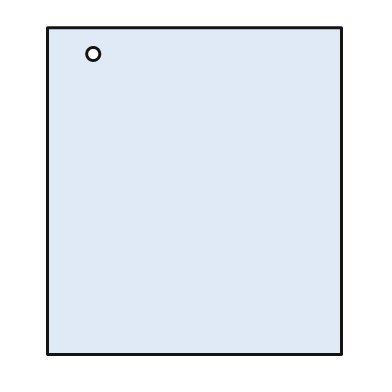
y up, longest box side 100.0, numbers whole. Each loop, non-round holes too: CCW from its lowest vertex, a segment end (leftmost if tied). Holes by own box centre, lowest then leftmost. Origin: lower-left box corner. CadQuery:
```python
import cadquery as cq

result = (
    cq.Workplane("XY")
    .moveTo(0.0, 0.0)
    .lineTo(90.0, 0.0)
    .lineTo(90.0, 100.0)
    .lineTo(0.0, 100.0)
    .close()
    .moveTo(14.0, 92.0)
    .circle(2.0)
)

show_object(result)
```